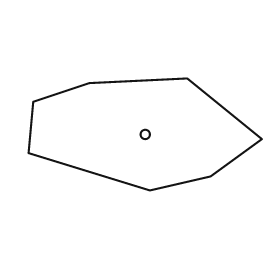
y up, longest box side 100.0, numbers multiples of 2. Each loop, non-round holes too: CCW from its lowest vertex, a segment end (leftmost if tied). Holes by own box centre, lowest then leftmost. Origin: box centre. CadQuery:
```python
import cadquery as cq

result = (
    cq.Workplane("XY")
    .moveTo(2.0, -24.0)
    .lineTo(28.0, -18.0)
    .lineTo(50.0, -2.0)
    .lineTo(18.0, 24.0)
    .lineTo(-24.0, 22.0)
    .lineTo(-48.0, 14.0)
    .lineTo(-50.0, -8.0)
    .close()
    .moveTo(0.0, 0.0)
    .circle(2.0)
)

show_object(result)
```